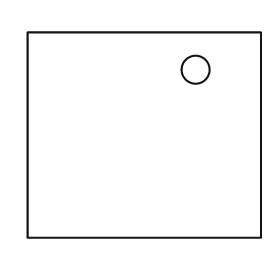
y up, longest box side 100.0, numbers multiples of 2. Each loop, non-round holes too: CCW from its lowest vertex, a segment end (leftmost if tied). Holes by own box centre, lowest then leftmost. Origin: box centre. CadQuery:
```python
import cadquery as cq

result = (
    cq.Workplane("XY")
    .moveTo(-50.0, -44.0)
    .lineTo(50.0, -44.0)
    .lineTo(50.0, 44.0)
    .lineTo(-50.0, 44.0)
    .close()
    .moveTo(22.0, 28.0)
    .circle(6.0)
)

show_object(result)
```